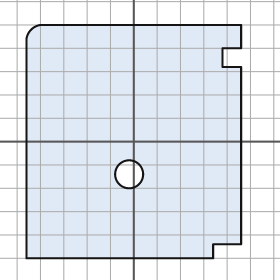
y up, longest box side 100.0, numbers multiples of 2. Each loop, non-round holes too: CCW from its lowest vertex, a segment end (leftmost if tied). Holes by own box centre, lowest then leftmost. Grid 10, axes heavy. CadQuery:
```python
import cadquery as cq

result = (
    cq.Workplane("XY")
    .moveTo(-46.0, -50.0)
    .lineTo(34.0, -50.0)
    .lineTo(34.0, -44.0)
    .lineTo(46.0, -44.0)
    .lineTo(46.0, 32.0)
    .lineTo(38.0, 32.0)
    .lineTo(38.0, 40.0)
    .lineTo(46.0, 40.0)
    .lineTo(46.0, 50.0)
    .lineTo(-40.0, 50.0)
    .threePointArc((-44.0, 48.0), (-46.0, 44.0))
    .close()
    .moveTo(-2.0, -14.0)
    .circle(6.0)
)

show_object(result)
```